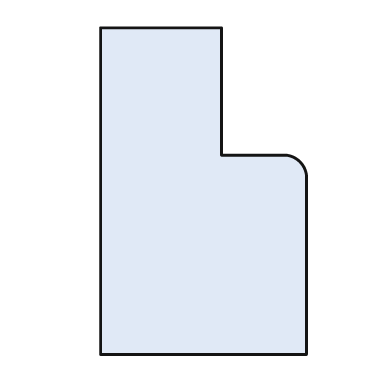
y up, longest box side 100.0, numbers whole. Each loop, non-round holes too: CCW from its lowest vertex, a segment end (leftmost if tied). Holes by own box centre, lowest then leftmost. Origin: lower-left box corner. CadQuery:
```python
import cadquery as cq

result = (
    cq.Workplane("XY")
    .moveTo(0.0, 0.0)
    .lineTo(63.0, 0.0)
    .lineTo(63.0, 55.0)
    .threePointArc((61.0, 59.0), (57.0, 61.0))
    .lineTo(37.0, 61.0)
    .lineTo(37.0, 100.0)
    .lineTo(0.0, 100.0)
    .close()
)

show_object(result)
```